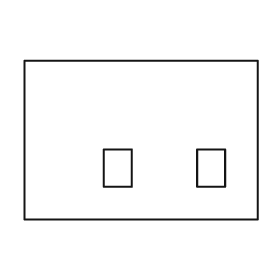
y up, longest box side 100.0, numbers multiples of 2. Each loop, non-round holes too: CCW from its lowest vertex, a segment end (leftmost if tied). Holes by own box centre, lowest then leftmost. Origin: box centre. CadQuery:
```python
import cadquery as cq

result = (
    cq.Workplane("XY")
    .moveTo(-50.0, -34.0)
    .lineTo(50.0, -34.0)
    .lineTo(50.0, 34.0)
    .lineTo(-50.0, 34.0)
    .close()
    .moveTo(-16.0, -20.0)
    .lineTo(-4.0, -20.0)
    .lineTo(-4.0, -4.0)
    .lineTo(-16.0, -4.0)
    .close()
    .moveTo(24.0, -20.0)
    .lineTo(36.0, -20.0)
    .lineTo(36.0, -4.0)
    .lineTo(24.0, -4.0)
    .close()
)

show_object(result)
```